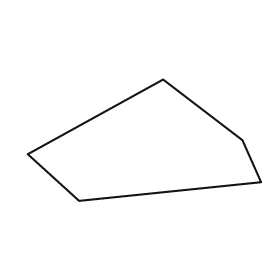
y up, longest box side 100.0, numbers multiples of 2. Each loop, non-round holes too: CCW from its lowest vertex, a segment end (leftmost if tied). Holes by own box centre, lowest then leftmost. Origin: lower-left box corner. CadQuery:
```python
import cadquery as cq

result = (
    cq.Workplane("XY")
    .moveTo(22.0, 0.0)
    .lineTo(100.0, 8.0)
    .lineTo(92.0, 26.0)
    .lineTo(58.0, 52.0)
    .lineTo(0.0, 20.0)
    .close()
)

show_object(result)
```